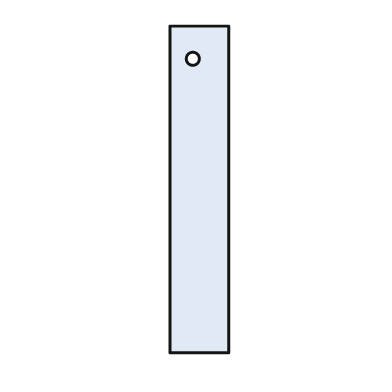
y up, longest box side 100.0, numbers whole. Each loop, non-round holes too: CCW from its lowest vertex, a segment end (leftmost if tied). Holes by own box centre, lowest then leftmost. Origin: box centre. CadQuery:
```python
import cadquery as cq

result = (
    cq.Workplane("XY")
    .moveTo(-9.0, -50.0)
    .lineTo(9.0, -50.0)
    .lineTo(9.0, 50.0)
    .lineTo(-9.0, 50.0)
    .close()
    .moveTo(-2.0, 40.0)
    .circle(2.0)
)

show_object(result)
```